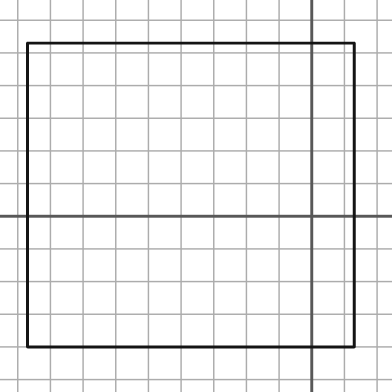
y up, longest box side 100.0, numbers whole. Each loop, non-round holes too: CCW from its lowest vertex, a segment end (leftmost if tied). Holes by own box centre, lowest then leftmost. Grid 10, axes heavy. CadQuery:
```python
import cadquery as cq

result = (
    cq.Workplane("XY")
    .moveTo(-87.0, -40.0)
    .lineTo(13.0, -40.0)
    .lineTo(13.0, 53.0)
    .lineTo(-87.0, 53.0)
    .close()
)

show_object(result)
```